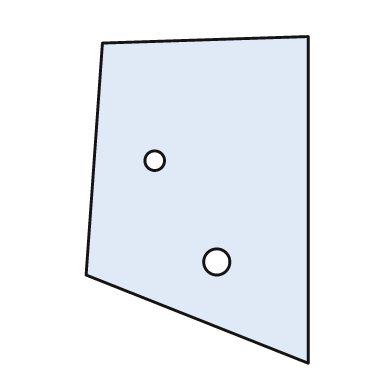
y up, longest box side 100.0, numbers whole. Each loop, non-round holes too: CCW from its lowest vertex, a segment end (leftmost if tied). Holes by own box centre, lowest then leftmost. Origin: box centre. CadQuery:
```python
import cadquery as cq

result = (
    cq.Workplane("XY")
    .moveTo(34.0, -50.0)
    .lineTo(34.0, 50.0)
    .lineTo(-29.0, 48.0)
    .lineTo(-34.0, -23.0)
    .close()
    .moveTo(6.0, -19.0)
    .circle(4.0)
    .moveTo(-13.0, 12.0)
    .circle(3.0)
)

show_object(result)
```